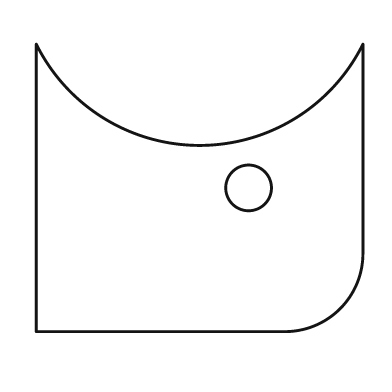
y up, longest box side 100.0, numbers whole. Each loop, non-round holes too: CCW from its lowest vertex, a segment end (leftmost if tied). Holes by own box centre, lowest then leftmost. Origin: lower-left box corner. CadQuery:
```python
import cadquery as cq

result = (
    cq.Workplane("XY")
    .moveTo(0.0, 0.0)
    .lineTo(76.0, 0.0)
    .threePointArc((93.0, 7.0), (100.0, 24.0))
    .lineTo(100.0, 88.0)
    .threePointArc((50.0, 57.0), (0.0, 88.0))
    .close()
    .moveTo(65.0, 44.0)
    .circle(7.0)
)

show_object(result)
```